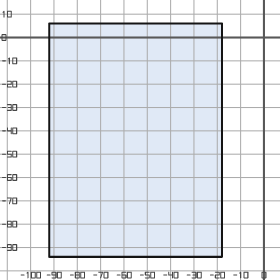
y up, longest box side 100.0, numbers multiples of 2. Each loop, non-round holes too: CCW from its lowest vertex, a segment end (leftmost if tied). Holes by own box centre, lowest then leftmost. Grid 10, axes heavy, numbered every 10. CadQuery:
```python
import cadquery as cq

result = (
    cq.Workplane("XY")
    .moveTo(-92.0, -94.0)
    .lineTo(-18.0, -94.0)
    .lineTo(-18.0, 6.0)
    .lineTo(-92.0, 6.0)
    .close()
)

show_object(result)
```